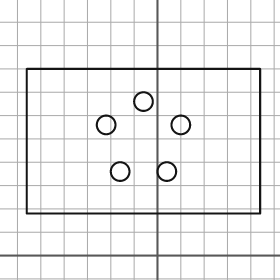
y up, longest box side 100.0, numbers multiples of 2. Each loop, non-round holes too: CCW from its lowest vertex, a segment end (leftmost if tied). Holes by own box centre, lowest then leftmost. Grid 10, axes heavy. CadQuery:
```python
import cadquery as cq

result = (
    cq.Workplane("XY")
    .moveTo(-56.0, 18.0)
    .lineTo(44.0, 18.0)
    .lineTo(44.0, 80.0)
    .lineTo(-56.0, 80.0)
    .close()
    .moveTo(-16.0, 36.0)
    .circle(4.0)
    .moveTo(4.0, 36.0)
    .circle(4.0)
    .moveTo(-22.0, 56.0)
    .circle(4.0)
    .moveTo(10.0, 56.0)
    .circle(4.0)
    .moveTo(-6.0, 66.0)
    .circle(4.0)
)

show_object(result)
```